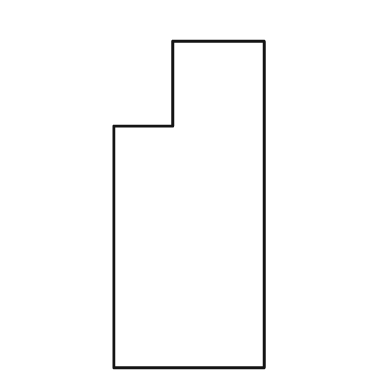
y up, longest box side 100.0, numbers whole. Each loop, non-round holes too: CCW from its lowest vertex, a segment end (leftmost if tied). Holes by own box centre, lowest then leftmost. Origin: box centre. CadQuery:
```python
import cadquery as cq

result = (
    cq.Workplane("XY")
    .moveTo(-23.0, -50.0)
    .lineTo(23.0, -50.0)
    .lineTo(23.0, 50.0)
    .lineTo(-5.0, 50.0)
    .lineTo(-5.0, 24.0)
    .lineTo(-23.0, 24.0)
    .close()
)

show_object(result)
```